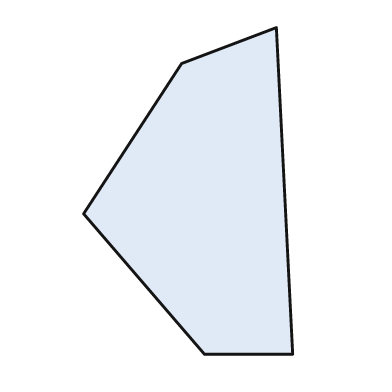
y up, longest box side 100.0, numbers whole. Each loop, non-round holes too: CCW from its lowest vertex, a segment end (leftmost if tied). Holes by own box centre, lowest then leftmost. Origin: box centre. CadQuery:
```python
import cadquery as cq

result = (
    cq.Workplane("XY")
    .moveTo(5.0, -50.0)
    .lineTo(32.0, -50.0)
    .lineTo(27.0, 50.0)
    .lineTo(-2.0, 39.0)
    .lineTo(-32.0, -7.0)
    .close()
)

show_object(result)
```